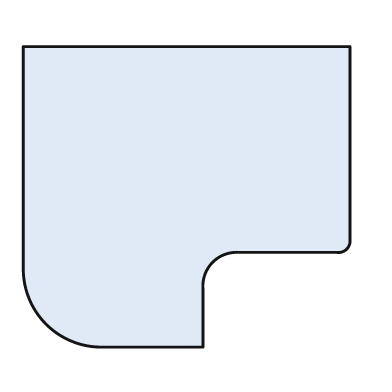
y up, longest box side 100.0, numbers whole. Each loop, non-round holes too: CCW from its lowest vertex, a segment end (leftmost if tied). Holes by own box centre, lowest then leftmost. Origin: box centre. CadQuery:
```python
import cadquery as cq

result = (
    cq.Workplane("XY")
    .moveTo(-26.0, -46.0)
    .lineTo(5.0, -46.0)
    .lineTo(5.0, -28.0)
    .threePointArc((8.0, -20.0), (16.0, -17.0))
    .lineTo(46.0, -17.0)
    .threePointArc((49.0, -16.0), (50.0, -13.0))
    .lineTo(50.0, 46.0)
    .lineTo(-50.0, 46.0)
    .lineTo(-50.0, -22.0)
    .threePointArc((-43.0, -39.0), (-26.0, -46.0))
    .close()
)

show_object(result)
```